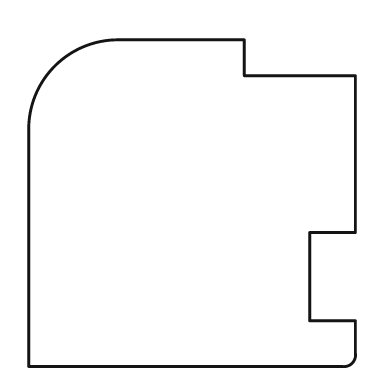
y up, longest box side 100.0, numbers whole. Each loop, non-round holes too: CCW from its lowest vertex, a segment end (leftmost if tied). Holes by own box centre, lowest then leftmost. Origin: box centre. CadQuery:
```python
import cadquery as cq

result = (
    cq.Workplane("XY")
    .moveTo(-50.0, -50.0)
    .lineTo(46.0, -50.0)
    .threePointArc((49.0, -49.0), (50.0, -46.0))
    .lineTo(50.0, -36.0)
    .lineTo(36.0, -36.0)
    .lineTo(36.0, -9.0)
    .lineTo(50.0, -9.0)
    .lineTo(50.0, 39.0)
    .lineTo(16.0, 39.0)
    .lineTo(16.0, 50.0)
    .lineTo(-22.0, 50.0)
    .threePointArc((-42.0, 42.0), (-50.0, 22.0))
    .close()
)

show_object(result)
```